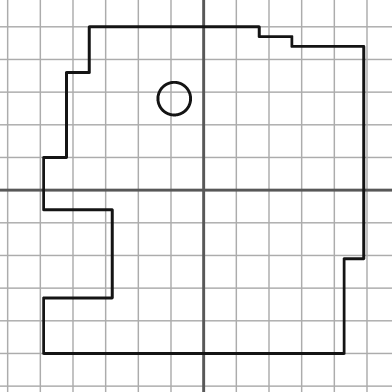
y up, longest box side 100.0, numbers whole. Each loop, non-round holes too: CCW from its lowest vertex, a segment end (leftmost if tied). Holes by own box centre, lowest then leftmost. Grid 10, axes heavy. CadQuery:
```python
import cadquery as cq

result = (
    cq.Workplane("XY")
    .moveTo(-49.0, -50.0)
    .lineTo(43.0, -50.0)
    .lineTo(43.0, -21.0)
    .lineTo(49.0, -21.0)
    .lineTo(49.0, 44.0)
    .lineTo(27.0, 44.0)
    .lineTo(27.0, 47.0)
    .lineTo(17.0, 47.0)
    .lineTo(17.0, 50.0)
    .lineTo(-35.0, 50.0)
    .lineTo(-35.0, 36.0)
    .lineTo(-42.0, 36.0)
    .lineTo(-42.0, 10.0)
    .lineTo(-49.0, 10.0)
    .lineTo(-49.0, -6.0)
    .lineTo(-28.0, -6.0)
    .lineTo(-28.0, -33.0)
    .lineTo(-49.0, -33.0)
    .close()
    .moveTo(-9.0, 28.0)
    .circle(5.0)
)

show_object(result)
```